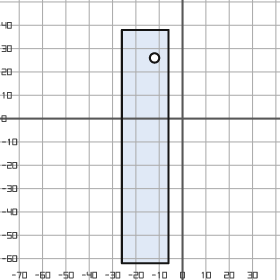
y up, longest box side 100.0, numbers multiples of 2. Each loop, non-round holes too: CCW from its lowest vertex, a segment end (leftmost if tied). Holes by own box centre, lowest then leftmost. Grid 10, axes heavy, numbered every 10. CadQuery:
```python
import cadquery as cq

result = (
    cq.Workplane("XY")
    .moveTo(-26.0, -62.0)
    .lineTo(-6.0, -62.0)
    .lineTo(-6.0, 38.0)
    .lineTo(-26.0, 38.0)
    .close()
    .moveTo(-12.0, 26.0)
    .circle(2.0)
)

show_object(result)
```